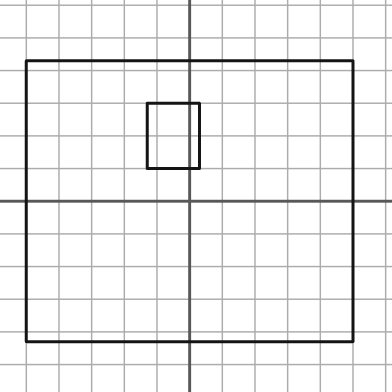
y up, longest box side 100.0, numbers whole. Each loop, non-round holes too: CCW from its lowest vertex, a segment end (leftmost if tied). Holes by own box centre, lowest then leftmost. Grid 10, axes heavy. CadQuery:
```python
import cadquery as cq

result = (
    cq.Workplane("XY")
    .moveTo(-50.0, -43.0)
    .lineTo(50.0, -43.0)
    .lineTo(50.0, 43.0)
    .lineTo(-50.0, 43.0)
    .close()
    .moveTo(-13.0, 10.0)
    .lineTo(3.0, 10.0)
    .lineTo(3.0, 30.0)
    .lineTo(-13.0, 30.0)
    .close()
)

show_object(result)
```